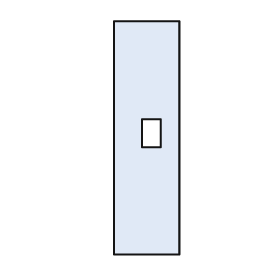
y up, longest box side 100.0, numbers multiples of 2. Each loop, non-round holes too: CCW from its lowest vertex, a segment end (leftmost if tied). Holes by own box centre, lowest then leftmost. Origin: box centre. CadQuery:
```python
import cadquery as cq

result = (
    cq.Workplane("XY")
    .moveTo(-14.0, -50.0)
    .lineTo(14.0, -50.0)
    .lineTo(14.0, 50.0)
    .lineTo(-14.0, 50.0)
    .close()
    .moveTo(-2.0, -4.0)
    .lineTo(6.0, -4.0)
    .lineTo(6.0, 8.0)
    .lineTo(-2.0, 8.0)
    .close()
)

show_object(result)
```